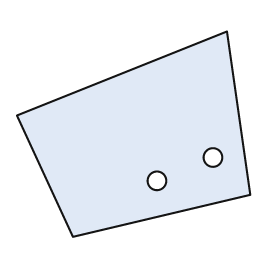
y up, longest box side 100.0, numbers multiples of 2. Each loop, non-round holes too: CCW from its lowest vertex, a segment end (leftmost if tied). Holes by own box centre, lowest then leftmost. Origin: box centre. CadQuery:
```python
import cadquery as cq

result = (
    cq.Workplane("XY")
    .moveTo(-26.0, -44.0)
    .lineTo(50.0, -26.0)
    .lineTo(40.0, 44.0)
    .lineTo(-50.0, 8.0)
    .close()
    .moveTo(10.0, -20.0)
    .circle(4.0)
    .moveTo(34.0, -10.0)
    .circle(4.0)
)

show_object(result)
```